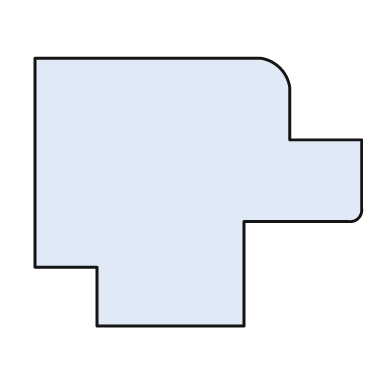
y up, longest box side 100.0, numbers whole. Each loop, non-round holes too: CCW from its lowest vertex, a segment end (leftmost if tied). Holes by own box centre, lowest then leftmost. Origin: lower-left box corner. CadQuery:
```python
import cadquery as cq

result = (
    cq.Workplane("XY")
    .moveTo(19.0, 0.0)
    .lineTo(64.0, 0.0)
    .lineTo(64.0, 32.0)
    .lineTo(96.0, 32.0)
    .threePointArc((99.0, 33.0), (100.0, 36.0))
    .lineTo(100.0, 57.0)
    .lineTo(78.0, 57.0)
    .lineTo(78.0, 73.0)
    .threePointArc((75.0, 79.0), (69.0, 82.0))
    .lineTo(0.0, 82.0)
    .lineTo(0.0, 18.0)
    .lineTo(19.0, 18.0)
    .close()
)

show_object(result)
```